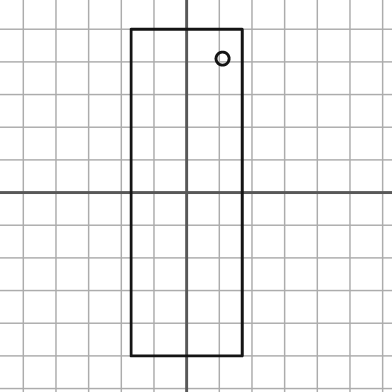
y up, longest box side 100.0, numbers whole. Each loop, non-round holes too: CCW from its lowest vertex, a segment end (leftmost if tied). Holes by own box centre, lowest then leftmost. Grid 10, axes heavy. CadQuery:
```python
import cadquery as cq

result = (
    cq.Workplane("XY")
    .moveTo(-17.0, -50.0)
    .lineTo(17.0, -50.0)
    .lineTo(17.0, 50.0)
    .lineTo(-17.0, 50.0)
    .close()
    .moveTo(11.0, 41.0)
    .circle(2.0)
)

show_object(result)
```